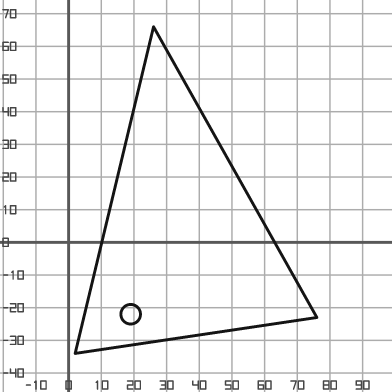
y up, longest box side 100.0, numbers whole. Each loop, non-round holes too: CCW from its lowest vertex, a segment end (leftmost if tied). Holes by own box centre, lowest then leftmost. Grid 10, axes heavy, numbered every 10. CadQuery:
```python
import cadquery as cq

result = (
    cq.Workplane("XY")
    .moveTo(2.0, -34.0)
    .lineTo(76.0, -23.0)
    .lineTo(26.0, 66.0)
    .close()
    .moveTo(19.0, -22.0)
    .circle(3.0)
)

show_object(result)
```